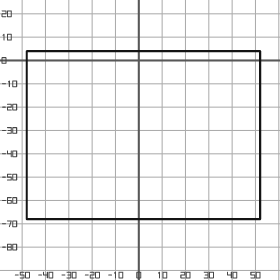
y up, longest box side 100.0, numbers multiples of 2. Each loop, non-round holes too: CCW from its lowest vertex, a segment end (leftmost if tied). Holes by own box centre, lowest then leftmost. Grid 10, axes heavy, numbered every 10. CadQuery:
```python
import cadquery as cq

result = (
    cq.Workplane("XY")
    .moveTo(-48.0, -68.0)
    .lineTo(52.0, -68.0)
    .lineTo(52.0, 4.0)
    .lineTo(-48.0, 4.0)
    .close()
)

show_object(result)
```